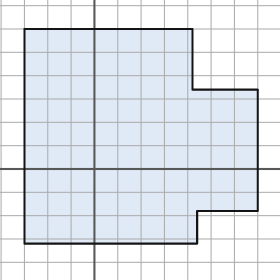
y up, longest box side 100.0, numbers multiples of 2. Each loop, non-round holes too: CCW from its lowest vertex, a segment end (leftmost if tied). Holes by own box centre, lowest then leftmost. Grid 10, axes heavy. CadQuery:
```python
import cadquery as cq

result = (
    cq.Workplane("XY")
    .moveTo(-30.0, -32.0)
    .lineTo(44.0, -32.0)
    .lineTo(44.0, -18.0)
    .lineTo(70.0, -18.0)
    .lineTo(70.0, 34.0)
    .lineTo(42.0, 34.0)
    .lineTo(42.0, 60.0)
    .lineTo(-30.0, 60.0)
    .close()
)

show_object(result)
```